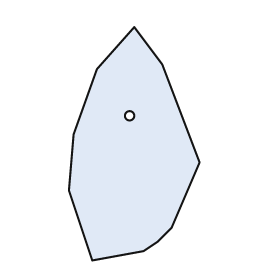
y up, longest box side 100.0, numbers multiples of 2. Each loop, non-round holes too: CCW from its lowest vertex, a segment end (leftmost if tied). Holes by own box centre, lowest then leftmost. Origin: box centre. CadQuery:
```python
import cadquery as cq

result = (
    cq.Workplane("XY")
    .moveTo(-18.0, -50.0)
    .lineTo(4.0, -46.0)
    .lineTo(10.0, -42.0)
    .lineTo(16.0, -36.0)
    .lineTo(28.0, -8.0)
    .lineTo(12.0, 34.0)
    .lineTo(0.0, 50.0)
    .lineTo(-16.0, 32.0)
    .lineTo(-26.0, 4.0)
    .lineTo(-28.0, -20.0)
    .close()
    .moveTo(-2.0, 12.0)
    .circle(2.0)
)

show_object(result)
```